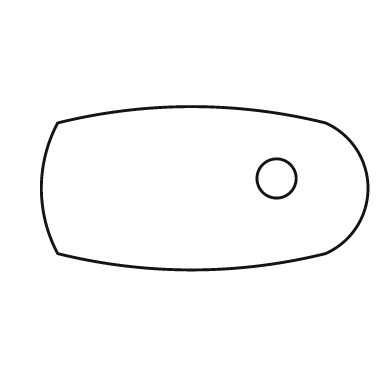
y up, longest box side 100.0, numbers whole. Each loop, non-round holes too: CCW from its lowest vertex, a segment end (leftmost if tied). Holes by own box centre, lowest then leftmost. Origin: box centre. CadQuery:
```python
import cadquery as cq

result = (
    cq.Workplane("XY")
    .moveTo(-45.0, -20.0)
    .threePointArc((-4.0, -25.0), (37.0, -20.0))
    .threePointArc((50.0, 0.0), (37.0, 20.0))
    .threePointArc((-4.0, 25.0), (-45.0, 20.0))
    .threePointArc((-50.0, 0.0), (-45.0, -20.0))
    .close()
    .moveTo(22.0, 3.0)
    .circle(6.0)
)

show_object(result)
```